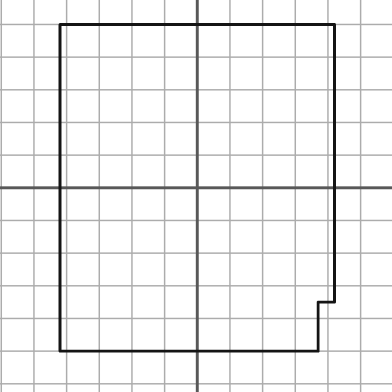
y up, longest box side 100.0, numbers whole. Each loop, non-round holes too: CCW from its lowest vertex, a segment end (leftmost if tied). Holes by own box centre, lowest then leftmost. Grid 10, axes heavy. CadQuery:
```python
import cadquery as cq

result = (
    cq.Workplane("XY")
    .moveTo(-42.0, -50.0)
    .lineTo(37.0, -50.0)
    .lineTo(37.0, -35.0)
    .lineTo(42.0, -35.0)
    .lineTo(42.0, 50.0)
    .lineTo(-42.0, 50.0)
    .close()
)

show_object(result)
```